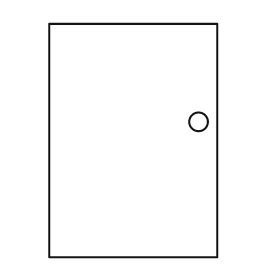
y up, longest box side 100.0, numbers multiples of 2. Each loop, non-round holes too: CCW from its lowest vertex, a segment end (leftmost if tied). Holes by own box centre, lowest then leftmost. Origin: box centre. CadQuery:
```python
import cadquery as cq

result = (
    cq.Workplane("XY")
    .moveTo(-36.0, -50.0)
    .lineTo(36.0, -50.0)
    .lineTo(36.0, 50.0)
    .lineTo(-36.0, 50.0)
    .close()
    .moveTo(28.0, 8.0)
    .circle(4.0)
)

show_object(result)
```